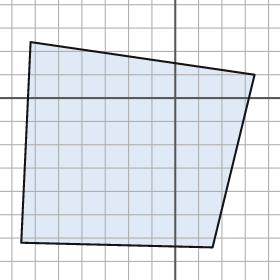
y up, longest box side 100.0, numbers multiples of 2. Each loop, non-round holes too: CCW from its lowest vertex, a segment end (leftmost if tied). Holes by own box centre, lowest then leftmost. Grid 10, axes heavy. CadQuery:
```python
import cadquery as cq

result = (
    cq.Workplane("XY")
    .moveTo(16.0, -64.0)
    .lineTo(34.0, 10.0)
    .lineTo(-62.0, 24.0)
    .lineTo(-66.0, -62.0)
    .close()
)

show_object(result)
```